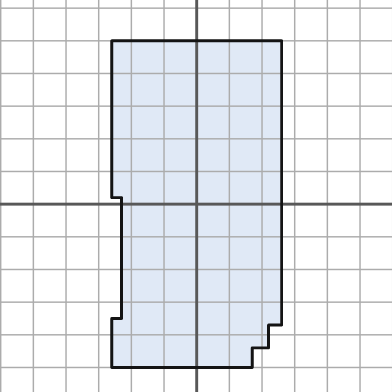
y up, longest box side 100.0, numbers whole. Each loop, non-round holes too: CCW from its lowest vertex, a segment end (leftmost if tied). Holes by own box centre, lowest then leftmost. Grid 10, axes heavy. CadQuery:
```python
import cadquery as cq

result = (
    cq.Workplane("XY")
    .moveTo(-26.0, -50.0)
    .lineTo(17.0, -50.0)
    .lineTo(17.0, -44.0)
    .lineTo(22.0, -44.0)
    .lineTo(22.0, -37.0)
    .lineTo(26.0, -37.0)
    .lineTo(26.0, 50.0)
    .lineTo(-26.0, 50.0)
    .lineTo(-26.0, 2.0)
    .lineTo(-23.0, 2.0)
    .lineTo(-23.0, -35.0)
    .lineTo(-26.0, -35.0)
    .close()
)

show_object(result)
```